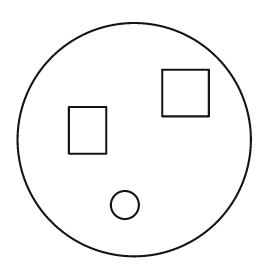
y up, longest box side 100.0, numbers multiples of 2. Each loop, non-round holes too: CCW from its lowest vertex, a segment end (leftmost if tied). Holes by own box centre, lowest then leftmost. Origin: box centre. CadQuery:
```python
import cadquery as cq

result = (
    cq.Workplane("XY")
    .moveTo(0.0, 0.0)
    .circle(50.0)
    .moveTo(-4.0, -28.0)
    .circle(6.0)
    .moveTo(-28.0, -6.0)
    .lineTo(-12.0, -6.0)
    .lineTo(-12.0, 14.0)
    .lineTo(-28.0, 14.0)
    .close()
    .moveTo(12.0, 10.0)
    .lineTo(32.0, 10.0)
    .lineTo(32.0, 30.0)
    .lineTo(12.0, 30.0)
    .close()
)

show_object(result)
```